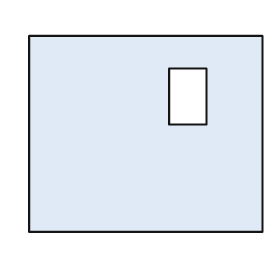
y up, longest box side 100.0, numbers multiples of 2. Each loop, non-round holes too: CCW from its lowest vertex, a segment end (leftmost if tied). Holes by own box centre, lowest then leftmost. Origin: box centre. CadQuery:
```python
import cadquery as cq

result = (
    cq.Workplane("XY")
    .moveTo(-50.0, -42.0)
    .lineTo(50.0, -42.0)
    .lineTo(50.0, 42.0)
    .lineTo(-50.0, 42.0)
    .close()
    .moveTo(10.0, 4.0)
    .lineTo(26.0, 4.0)
    .lineTo(26.0, 28.0)
    .lineTo(10.0, 28.0)
    .close()
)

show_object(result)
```